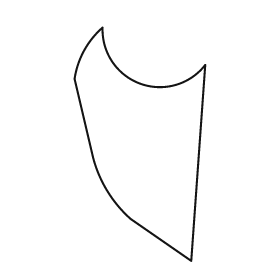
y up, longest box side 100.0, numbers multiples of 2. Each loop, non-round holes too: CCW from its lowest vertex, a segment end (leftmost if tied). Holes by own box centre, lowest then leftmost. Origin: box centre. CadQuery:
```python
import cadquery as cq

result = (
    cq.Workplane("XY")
    .moveTo(22.0, -50.0)
    .lineTo(28.0, 34.0)
    .threePointArc((0.0, 26.0), (-16.0, 50.0))
    .threePointArc((-24.0, 40.0), (-28.0, 28.0))
    .lineTo(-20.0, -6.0)
    .threePointArc((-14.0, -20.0), (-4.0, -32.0))
    .close()
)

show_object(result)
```